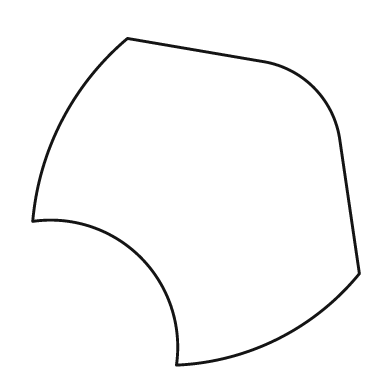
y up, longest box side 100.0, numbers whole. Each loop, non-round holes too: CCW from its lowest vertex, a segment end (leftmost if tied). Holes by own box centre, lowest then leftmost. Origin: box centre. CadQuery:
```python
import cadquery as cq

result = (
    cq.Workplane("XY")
    .moveTo(-6.0, -50.0)
    .threePointArc((25.0, -42.0), (50.0, -22.0))
    .lineTo(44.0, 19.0)
    .threePointArc((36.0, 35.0), (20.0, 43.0))
    .lineTo(-21.0, 50.0)
    .threePointArc((-41.0, 25.0), (-50.0, -6.0))
    .threePointArc((-17.0, -17.0), (-6.0, -50.0))
    .close()
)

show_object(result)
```